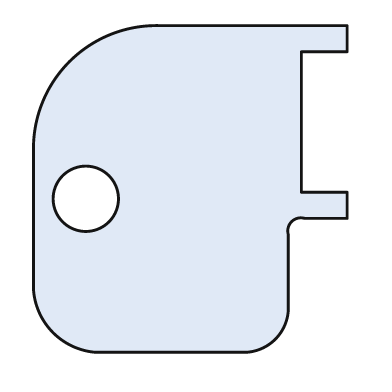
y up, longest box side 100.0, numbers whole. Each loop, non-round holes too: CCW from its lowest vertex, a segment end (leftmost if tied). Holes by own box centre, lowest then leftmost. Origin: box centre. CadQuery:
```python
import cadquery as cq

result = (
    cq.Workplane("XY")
    .moveTo(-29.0, -50.0)
    .lineTo(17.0, -50.0)
    .threePointArc((26.0, -46.0), (30.0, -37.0))
    .lineTo(30.0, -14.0)
    .threePointArc((31.0, -10.0), (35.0, -9.0))
    .lineTo(48.0, -9.0)
    .lineTo(48.0, -1.0)
    .lineTo(34.0, -1.0)
    .lineTo(34.0, 42.0)
    .lineTo(48.0, 42.0)
    .lineTo(48.0, 50.0)
    .lineTo(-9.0, 50.0)
    .threePointArc((-37.0, 39.0), (-48.0, 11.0))
    .lineTo(-48.0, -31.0)
    .threePointArc((-42.0, -44.0), (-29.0, -50.0))
    .close()
    .moveTo(-32.0, -3.0)
    .circle(10.0)
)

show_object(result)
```